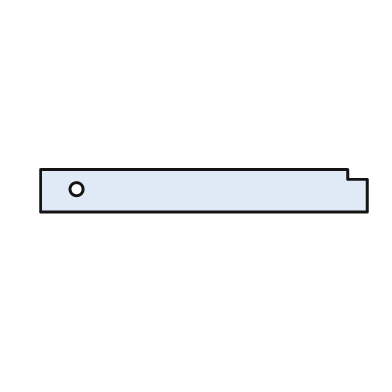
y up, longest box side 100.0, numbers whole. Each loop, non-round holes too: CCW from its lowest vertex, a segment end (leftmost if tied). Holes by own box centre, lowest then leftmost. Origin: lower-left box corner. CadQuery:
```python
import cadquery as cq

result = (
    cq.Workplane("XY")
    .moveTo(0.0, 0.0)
    .lineTo(100.0, 0.0)
    .lineTo(100.0, 10.0)
    .lineTo(94.0, 10.0)
    .lineTo(94.0, 13.0)
    .lineTo(0.0, 13.0)
    .close()
    .moveTo(11.0, 7.0)
    .circle(2.0)
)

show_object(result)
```